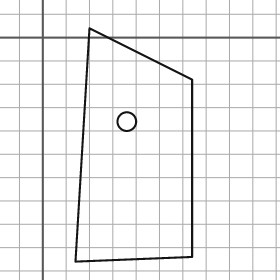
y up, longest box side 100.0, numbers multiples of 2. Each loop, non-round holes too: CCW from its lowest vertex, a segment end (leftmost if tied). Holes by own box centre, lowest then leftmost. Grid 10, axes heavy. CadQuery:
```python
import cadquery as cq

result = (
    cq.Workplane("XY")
    .moveTo(14.0, -96.0)
    .lineTo(64.0, -94.0)
    .lineTo(64.0, -18.0)
    .lineTo(20.0, 4.0)
    .close()
    .moveTo(36.0, -36.0)
    .circle(4.0)
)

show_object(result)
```